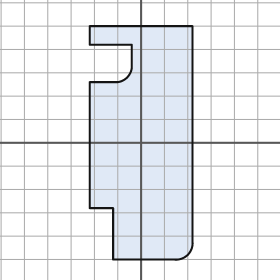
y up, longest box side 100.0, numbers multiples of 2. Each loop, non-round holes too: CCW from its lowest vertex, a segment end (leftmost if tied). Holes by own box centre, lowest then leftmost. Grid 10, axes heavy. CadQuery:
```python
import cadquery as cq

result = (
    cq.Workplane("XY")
    .moveTo(-12.0, -50.0)
    .lineTo(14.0, -50.0)
    .threePointArc((20.0, -48.0), (22.0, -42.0))
    .lineTo(22.0, 50.0)
    .lineTo(-22.0, 50.0)
    .lineTo(-22.0, 42.0)
    .lineTo(-4.0, 42.0)
    .lineTo(-4.0, 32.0)
    .threePointArc((-6.0, 28.0), (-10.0, 26.0))
    .lineTo(-22.0, 26.0)
    .lineTo(-22.0, -28.0)
    .lineTo(-12.0, -28.0)
    .close()
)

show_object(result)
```